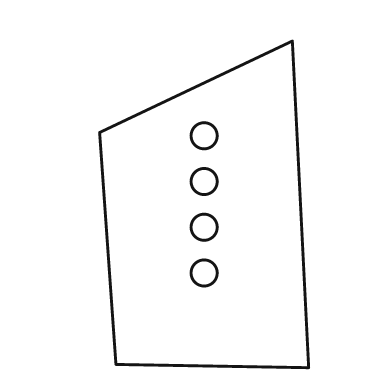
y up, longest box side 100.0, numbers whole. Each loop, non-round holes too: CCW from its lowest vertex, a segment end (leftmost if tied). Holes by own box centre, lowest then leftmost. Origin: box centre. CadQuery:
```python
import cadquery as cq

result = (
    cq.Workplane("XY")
    .moveTo(32.0, -50.0)
    .lineTo(27.0, 50.0)
    .lineTo(-32.0, 22.0)
    .lineTo(-27.0, -49.0)
    .close()
    .moveTo(0.0, -21.0)
    .circle(4.0)
    .moveTo(0.0, -7.0)
    .circle(4.0)
    .moveTo(0.0, 7.0)
    .circle(4.0)
    .moveTo(0.0, 21.0)
    .circle(4.0)
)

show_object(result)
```